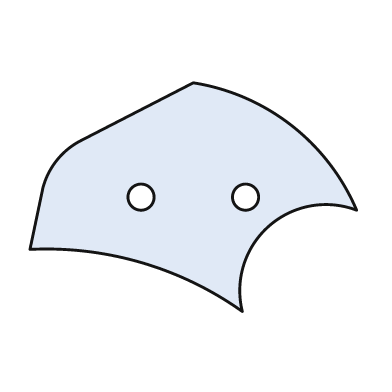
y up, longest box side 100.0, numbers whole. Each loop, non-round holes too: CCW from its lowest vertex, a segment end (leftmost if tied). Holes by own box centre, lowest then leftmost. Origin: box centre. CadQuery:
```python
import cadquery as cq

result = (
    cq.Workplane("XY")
    .moveTo(15.0, -35.0)
    .threePointArc((23.0, -9.0), (50.0, -4.0))
    .threePointArc((30.0, 22.0), (0.0, 35.0))
    .lineTo(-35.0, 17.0)
    .threePointArc((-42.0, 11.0), (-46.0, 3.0))
    .lineTo(-50.0, -16.0)
    .threePointArc((-16.0, -20.0), (15.0, -35.0))
    .close()
    .moveTo(-16.0, 0.0)
    .circle(4.0)
    .moveTo(16.0, 0.0)
    .circle(4.0)
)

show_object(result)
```